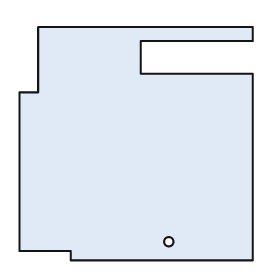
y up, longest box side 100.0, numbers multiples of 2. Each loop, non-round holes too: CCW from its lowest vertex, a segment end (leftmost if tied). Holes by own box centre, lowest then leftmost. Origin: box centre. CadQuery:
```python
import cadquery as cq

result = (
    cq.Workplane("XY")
    .moveTo(-28.0, -50.0)
    .lineTo(50.0, -50.0)
    .lineTo(50.0, 30.0)
    .lineTo(2.0, 30.0)
    .lineTo(2.0, 44.0)
    .lineTo(50.0, 44.0)
    .lineTo(50.0, 50.0)
    .lineTo(-42.0, 50.0)
    .lineTo(-42.0, 22.0)
    .lineTo(-50.0, 22.0)
    .lineTo(-50.0, -46.0)
    .lineTo(-28.0, -46.0)
    .close()
    .moveTo(14.0, -42.0)
    .circle(2.0)
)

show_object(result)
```